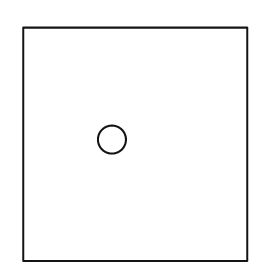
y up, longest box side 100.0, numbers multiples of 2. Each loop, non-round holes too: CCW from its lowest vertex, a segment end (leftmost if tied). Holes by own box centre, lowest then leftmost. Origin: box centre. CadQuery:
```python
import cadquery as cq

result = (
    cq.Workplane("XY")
    .moveTo(-48.0, -50.0)
    .lineTo(48.0, -50.0)
    .lineTo(48.0, 50.0)
    .lineTo(-48.0, 50.0)
    .close()
    .moveTo(-10.0, 2.0)
    .circle(6.0)
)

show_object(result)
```